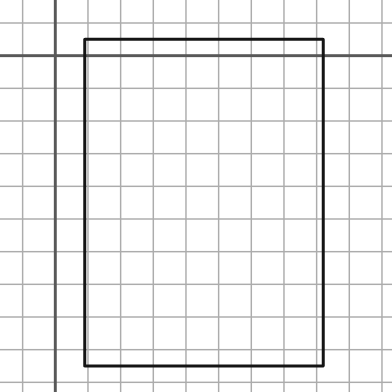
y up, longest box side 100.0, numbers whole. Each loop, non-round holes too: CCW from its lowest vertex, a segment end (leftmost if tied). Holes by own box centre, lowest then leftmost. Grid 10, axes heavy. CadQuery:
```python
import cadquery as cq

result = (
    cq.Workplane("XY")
    .moveTo(9.0, -95.0)
    .lineTo(82.0, -95.0)
    .lineTo(82.0, 5.0)
    .lineTo(9.0, 5.0)
    .close()
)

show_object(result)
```